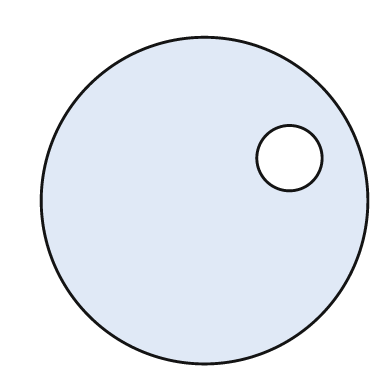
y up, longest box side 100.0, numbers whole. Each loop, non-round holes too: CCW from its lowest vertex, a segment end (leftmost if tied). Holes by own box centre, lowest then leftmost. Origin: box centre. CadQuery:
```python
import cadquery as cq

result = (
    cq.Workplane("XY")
    .moveTo(0.0, 0.0)
    .circle(50.0)
    .moveTo(26.0, 13.0)
    .circle(10.0)
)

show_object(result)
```